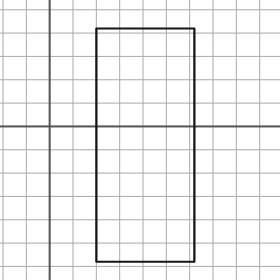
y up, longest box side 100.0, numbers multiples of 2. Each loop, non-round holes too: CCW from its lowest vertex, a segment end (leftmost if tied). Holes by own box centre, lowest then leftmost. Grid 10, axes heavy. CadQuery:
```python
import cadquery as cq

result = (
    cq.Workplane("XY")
    .moveTo(20.0, -58.0)
    .lineTo(62.0, -58.0)
    .lineTo(62.0, 42.0)
    .lineTo(20.0, 42.0)
    .close()
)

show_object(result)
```